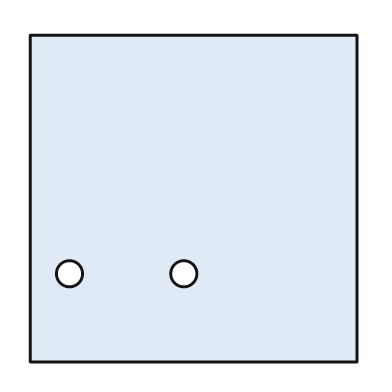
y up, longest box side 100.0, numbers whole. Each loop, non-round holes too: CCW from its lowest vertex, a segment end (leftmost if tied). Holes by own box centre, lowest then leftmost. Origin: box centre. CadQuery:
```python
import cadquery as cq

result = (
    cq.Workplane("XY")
    .moveTo(-50.0, -50.0)
    .lineTo(50.0, -50.0)
    .lineTo(50.0, 50.0)
    .lineTo(-50.0, 50.0)
    .close()
    .moveTo(-38.0, -23.0)
    .circle(4.0)
    .moveTo(-3.0, -23.0)
    .circle(4.0)
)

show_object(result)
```